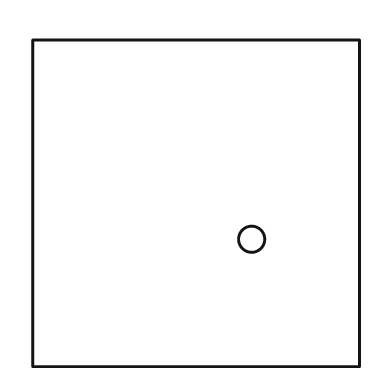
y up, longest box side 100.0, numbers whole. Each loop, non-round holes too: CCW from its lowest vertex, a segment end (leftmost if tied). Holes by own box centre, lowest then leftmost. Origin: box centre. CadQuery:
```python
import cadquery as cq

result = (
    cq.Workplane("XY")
    .moveTo(-50.0, -50.0)
    .lineTo(50.0, -50.0)
    .lineTo(50.0, 50.0)
    .lineTo(-50.0, 50.0)
    .close()
    .moveTo(17.0, -11.0)
    .circle(4.0)
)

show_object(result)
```